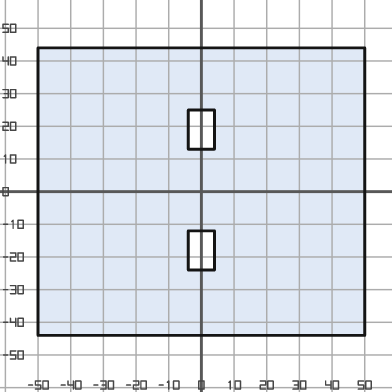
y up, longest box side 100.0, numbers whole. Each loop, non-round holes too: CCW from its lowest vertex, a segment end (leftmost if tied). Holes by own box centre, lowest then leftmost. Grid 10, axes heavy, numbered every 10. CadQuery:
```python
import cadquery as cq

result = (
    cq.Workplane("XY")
    .moveTo(-50.0, -44.0)
    .lineTo(50.0, -44.0)
    .lineTo(50.0, 44.0)
    .lineTo(-50.0, 44.0)
    .close()
    .moveTo(-4.0, -24.0)
    .lineTo(4.0, -24.0)
    .lineTo(4.0, -12.0)
    .lineTo(-4.0, -12.0)
    .close()
    .moveTo(-4.0, 13.0)
    .lineTo(4.0, 13.0)
    .lineTo(4.0, 25.0)
    .lineTo(-4.0, 25.0)
    .close()
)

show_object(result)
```